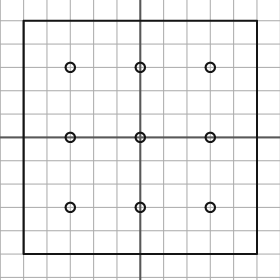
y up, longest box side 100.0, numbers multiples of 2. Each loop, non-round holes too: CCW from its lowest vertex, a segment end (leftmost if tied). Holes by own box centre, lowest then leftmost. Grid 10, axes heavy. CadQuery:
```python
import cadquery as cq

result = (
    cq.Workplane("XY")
    .moveTo(-50.0, -50.0)
    .lineTo(50.0, -50.0)
    .lineTo(50.0, 50.0)
    .lineTo(-50.0, 50.0)
    .close()
    .moveTo(-30.0, -30.0)
    .circle(2.0)
    .moveTo(0.0, -30.0)
    .circle(2.0)
    .moveTo(30.0, -30.0)
    .circle(2.0)
    .moveTo(-30.0, 0.0)
    .circle(2.0)
    .moveTo(0.0, 0.0)
    .circle(2.0)
    .moveTo(30.0, 0.0)
    .circle(2.0)
    .moveTo(-30.0, 30.0)
    .circle(2.0)
    .moveTo(0.0, 30.0)
    .circle(2.0)
    .moveTo(30.0, 30.0)
    .circle(2.0)
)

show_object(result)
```